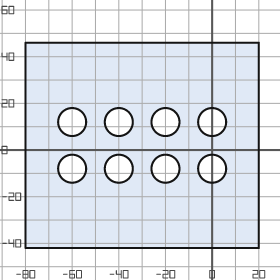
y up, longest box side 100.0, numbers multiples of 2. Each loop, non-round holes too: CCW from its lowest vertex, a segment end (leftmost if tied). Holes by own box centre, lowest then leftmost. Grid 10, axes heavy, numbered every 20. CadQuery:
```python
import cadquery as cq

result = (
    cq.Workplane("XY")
    .moveTo(-80.0, -42.0)
    .lineTo(20.0, -42.0)
    .lineTo(20.0, 46.0)
    .lineTo(-80.0, 46.0)
    .close()
    .moveTo(-60.0, -8.0)
    .circle(6.0)
    .moveTo(-40.0, -8.0)
    .circle(6.0)
    .moveTo(-20.0, -8.0)
    .circle(6.0)
    .moveTo(0.0, -8.0)
    .circle(6.0)
    .moveTo(-60.0, 12.0)
    .circle(6.0)
    .moveTo(-40.0, 12.0)
    .circle(6.0)
    .moveTo(-20.0, 12.0)
    .circle(6.0)
    .moveTo(0.0, 12.0)
    .circle(6.0)
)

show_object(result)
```